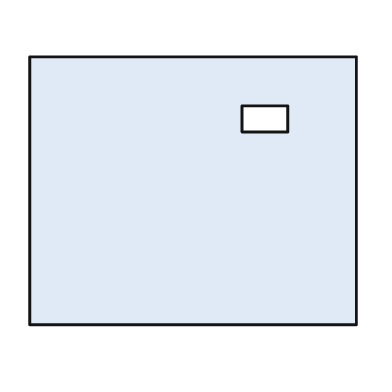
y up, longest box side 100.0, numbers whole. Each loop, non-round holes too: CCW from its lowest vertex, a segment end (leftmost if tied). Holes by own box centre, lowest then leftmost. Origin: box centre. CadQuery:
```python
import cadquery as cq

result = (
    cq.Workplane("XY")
    .moveTo(-50.0, -41.0)
    .lineTo(50.0, -41.0)
    .lineTo(50.0, 41.0)
    .lineTo(-50.0, 41.0)
    .close()
    .moveTo(15.0, 18.0)
    .lineTo(29.0, 18.0)
    .lineTo(29.0, 26.0)
    .lineTo(15.0, 26.0)
    .close()
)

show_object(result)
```